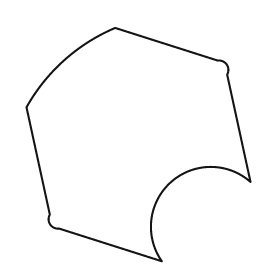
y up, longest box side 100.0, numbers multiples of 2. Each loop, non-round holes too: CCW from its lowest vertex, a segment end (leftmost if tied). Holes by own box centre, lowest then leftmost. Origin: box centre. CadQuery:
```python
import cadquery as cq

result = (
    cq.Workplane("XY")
    .moveTo(10.0, -50.0)
    .threePointArc((14.0, -16.0), (48.0, -16.0))
    .lineTo(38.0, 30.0)
    .threePointArc((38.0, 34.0), (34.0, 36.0))
    .lineTo(-10.0, 50.0)
    .threePointArc((-32.0, 36.0), (-48.0, 16.0))
    .lineTo(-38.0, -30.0)
    .threePointArc((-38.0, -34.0), (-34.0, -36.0))
    .close()
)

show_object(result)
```